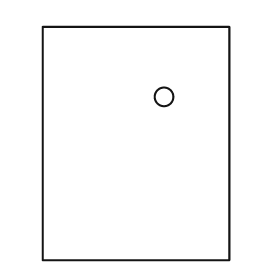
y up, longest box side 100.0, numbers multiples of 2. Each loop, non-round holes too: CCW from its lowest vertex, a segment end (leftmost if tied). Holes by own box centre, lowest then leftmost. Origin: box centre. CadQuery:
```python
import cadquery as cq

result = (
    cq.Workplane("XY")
    .moveTo(-40.0, -50.0)
    .lineTo(40.0, -50.0)
    .lineTo(40.0, 50.0)
    .lineTo(-40.0, 50.0)
    .close()
    .moveTo(12.0, 20.0)
    .circle(4.0)
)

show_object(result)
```